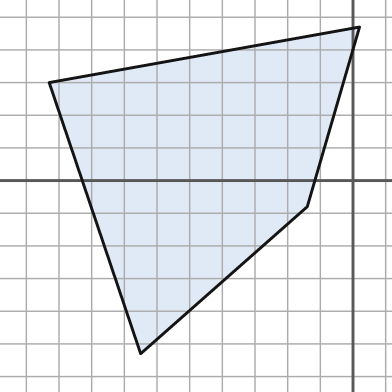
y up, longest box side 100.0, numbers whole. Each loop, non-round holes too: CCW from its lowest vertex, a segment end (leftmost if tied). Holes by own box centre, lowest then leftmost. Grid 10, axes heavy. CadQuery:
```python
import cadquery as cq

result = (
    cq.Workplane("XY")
    .moveTo(-65.0, -53.0)
    .lineTo(-14.0, -8.0)
    .lineTo(2.0, 47.0)
    .lineTo(-93.0, 30.0)
    .close()
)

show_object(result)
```